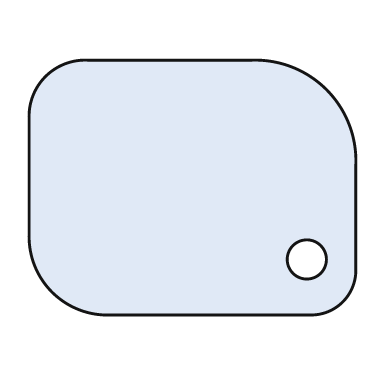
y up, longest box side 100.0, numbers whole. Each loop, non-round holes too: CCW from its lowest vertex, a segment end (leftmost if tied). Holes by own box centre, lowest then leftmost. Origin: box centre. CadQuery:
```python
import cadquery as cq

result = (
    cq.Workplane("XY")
    .moveTo(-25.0, -39.0)
    .lineTo(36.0, -39.0)
    .threePointArc((46.0, -35.0), (50.0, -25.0))
    .lineTo(50.0, 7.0)
    .threePointArc((41.0, 30.0), (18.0, 39.0))
    .lineTo(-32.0, 39.0)
    .threePointArc((-45.0, 34.0), (-50.0, 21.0))
    .lineTo(-50.0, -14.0)
    .threePointArc((-43.0, -32.0), (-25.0, -39.0))
    .close()
    .moveTo(35.0, -22.0)
    .circle(6.0)
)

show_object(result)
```